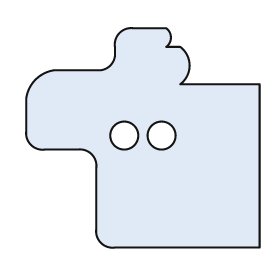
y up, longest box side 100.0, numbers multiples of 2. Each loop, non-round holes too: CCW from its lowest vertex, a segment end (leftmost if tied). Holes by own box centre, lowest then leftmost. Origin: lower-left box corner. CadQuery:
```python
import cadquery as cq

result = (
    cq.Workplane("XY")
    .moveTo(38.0, 0.0)
    .lineTo(100.0, 0.0)
    .lineTo(100.0, 70.0)
    .lineTo(66.0, 70.0)
    .threePointArc((70.0, 78.0), (66.0, 86.0))
    .lineTo(60.0, 86.0)
    .threePointArc((62.0, 90.0), (60.0, 94.0))
    .lineTo(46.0, 94.0)
    .threePointArc((40.0, 92.0), (38.0, 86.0))
    .lineTo(38.0, 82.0)
    .threePointArc((36.0, 78.0), (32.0, 76.0))
    .lineTo(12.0, 76.0)
    .threePointArc((4.0, 72.0), (0.0, 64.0))
    .lineTo(0.0, 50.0)
    .threePointArc((2.0, 44.0), (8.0, 42.0))
    .lineTo(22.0, 42.0)
    .threePointArc((28.0, 40.0), (30.0, 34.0))
    .lineTo(30.0, 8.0)
    .threePointArc((32.0, 2.0), (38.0, 0.0))
    .close()
    .moveTo(42.0, 48.0)
    .circle(6.0)
    .moveTo(58.0, 48.0)
    .circle(6.0)
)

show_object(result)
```